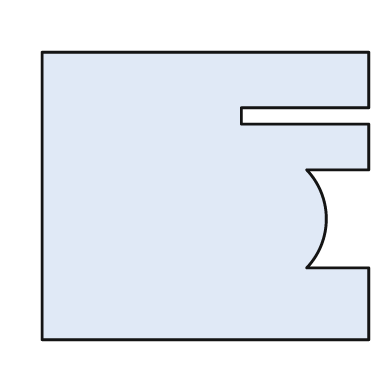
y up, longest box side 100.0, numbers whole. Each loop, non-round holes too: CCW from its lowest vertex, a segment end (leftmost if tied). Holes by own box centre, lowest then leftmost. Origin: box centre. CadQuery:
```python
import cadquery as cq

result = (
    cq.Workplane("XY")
    .moveTo(-50.0, -44.0)
    .lineTo(50.0, -44.0)
    .lineTo(50.0, -22.0)
    .lineTo(31.0, -22.0)
    .threePointArc((37.0, -7.0), (31.0, 8.0))
    .lineTo(50.0, 8.0)
    .lineTo(50.0, 22.0)
    .lineTo(11.0, 22.0)
    .lineTo(11.0, 27.0)
    .lineTo(50.0, 27.0)
    .lineTo(50.0, 44.0)
    .lineTo(-50.0, 44.0)
    .close()
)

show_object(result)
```